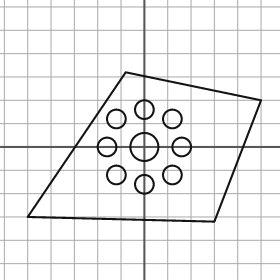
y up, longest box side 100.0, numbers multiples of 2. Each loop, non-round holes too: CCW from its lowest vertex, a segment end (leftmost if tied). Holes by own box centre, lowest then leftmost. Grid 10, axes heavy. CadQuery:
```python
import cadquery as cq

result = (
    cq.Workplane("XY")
    .moveTo(30.0, -32.0)
    .lineTo(50.0, 20.0)
    .lineTo(-8.0, 32.0)
    .lineTo(-50.0, -30.0)
    .close()
    .moveTo(0.0, -16.0)
    .circle(4.0)
    .moveTo(-12.0, -12.0)
    .circle(4.0)
    .moveTo(12.0, -12.0)
    .circle(4.0)
    .moveTo(-16.0, 0.0)
    .circle(4.0)
    .moveTo(0.0, 0.0)
    .circle(6.0)
    .moveTo(16.0, 0.0)
    .circle(4.0)
    .moveTo(-12.0, 12.0)
    .circle(4.0)
    .moveTo(12.0, 12.0)
    .circle(4.0)
    .moveTo(0.0, 16.0)
    .circle(4.0)
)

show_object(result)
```